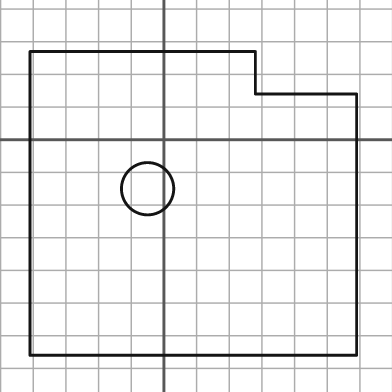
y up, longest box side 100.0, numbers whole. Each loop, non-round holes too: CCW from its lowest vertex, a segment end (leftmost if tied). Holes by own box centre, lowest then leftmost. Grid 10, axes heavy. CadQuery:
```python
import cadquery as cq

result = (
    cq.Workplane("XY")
    .moveTo(-41.0, -66.0)
    .lineTo(59.0, -66.0)
    .lineTo(59.0, 14.0)
    .lineTo(28.0, 14.0)
    .lineTo(28.0, 27.0)
    .lineTo(-41.0, 27.0)
    .close()
    .moveTo(-5.0, -15.0)
    .circle(8.0)
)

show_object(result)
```